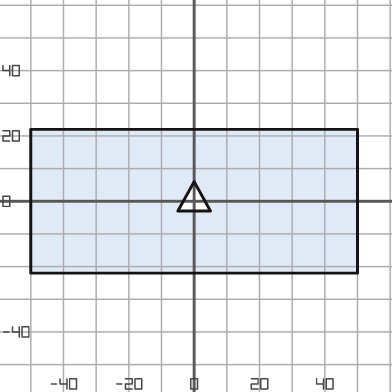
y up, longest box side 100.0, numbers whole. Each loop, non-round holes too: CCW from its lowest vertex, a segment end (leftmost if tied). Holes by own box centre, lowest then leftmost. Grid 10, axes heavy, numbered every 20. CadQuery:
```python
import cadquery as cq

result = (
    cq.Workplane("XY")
    .moveTo(-50.0, -22.0)
    .lineTo(50.0, -22.0)
    .lineTo(50.0, 22.0)
    .lineTo(-50.0, 22.0)
    .close()
    .moveTo(-5.0, -3.0)
    .lineTo(5.0, -3.0)
    .lineTo(0.0, 6.0)
    .close()
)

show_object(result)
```